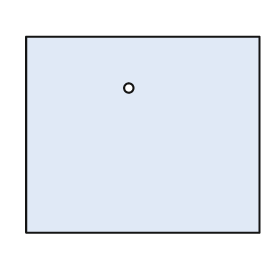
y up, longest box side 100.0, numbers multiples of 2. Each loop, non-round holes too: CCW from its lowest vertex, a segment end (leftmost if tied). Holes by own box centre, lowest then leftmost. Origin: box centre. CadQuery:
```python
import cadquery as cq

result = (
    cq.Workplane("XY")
    .moveTo(-50.0, -42.0)
    .lineTo(50.0, -42.0)
    .lineTo(50.0, 42.0)
    .lineTo(-50.0, 42.0)
    .close()
    .moveTo(-6.0, 20.0)
    .circle(2.0)
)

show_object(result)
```